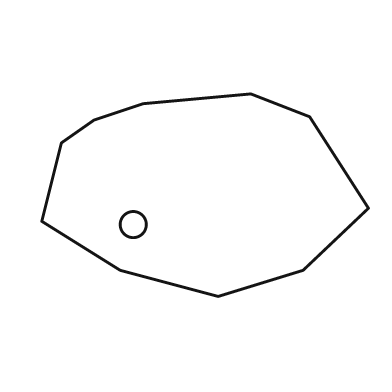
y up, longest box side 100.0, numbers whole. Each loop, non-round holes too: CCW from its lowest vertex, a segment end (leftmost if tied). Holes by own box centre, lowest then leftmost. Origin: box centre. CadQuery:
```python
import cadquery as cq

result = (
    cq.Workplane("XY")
    .moveTo(4.0, -31.0)
    .lineTo(30.0, -23.0)
    .lineTo(50.0, -4.0)
    .lineTo(32.0, 24.0)
    .lineTo(14.0, 31.0)
    .lineTo(-19.0, 28.0)
    .lineTo(-34.0, 23.0)
    .lineTo(-44.0, 16.0)
    .lineTo(-50.0, -8.0)
    .lineTo(-26.0, -23.0)
    .close()
    .moveTo(-22.0, -9.0)
    .circle(4.0)
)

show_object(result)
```